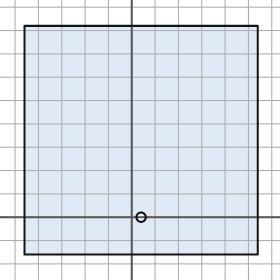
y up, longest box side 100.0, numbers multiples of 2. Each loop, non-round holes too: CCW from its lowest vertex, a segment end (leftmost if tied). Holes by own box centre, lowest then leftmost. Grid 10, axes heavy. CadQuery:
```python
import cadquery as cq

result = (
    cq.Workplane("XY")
    .moveTo(-46.0, -16.0)
    .lineTo(54.0, -16.0)
    .lineTo(54.0, 82.0)
    .lineTo(-46.0, 82.0)
    .close()
    .moveTo(4.0, 0.0)
    .circle(2.0)
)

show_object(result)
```